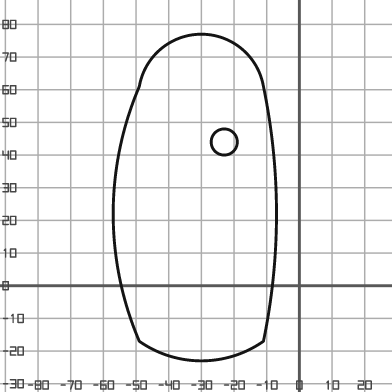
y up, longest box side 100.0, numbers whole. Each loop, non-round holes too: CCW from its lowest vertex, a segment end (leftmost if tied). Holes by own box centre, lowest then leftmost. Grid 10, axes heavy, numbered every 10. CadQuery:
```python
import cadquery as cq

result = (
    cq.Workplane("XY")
    .moveTo(-49.0, -17.0)
    .threePointArc((-30.0, -23.0), (-11.0, -17.0))
    .threePointArc((-7.0, 22.0), (-11.0, 61.0))
    .threePointArc((-30.0, 77.0), (-49.0, 61.0))
    .threePointArc((-57.0, 22.0), (-49.0, -17.0))
    .close()
    .moveTo(-23.0, 44.0)
    .circle(4.0)
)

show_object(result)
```